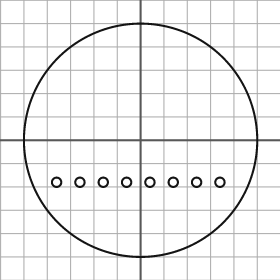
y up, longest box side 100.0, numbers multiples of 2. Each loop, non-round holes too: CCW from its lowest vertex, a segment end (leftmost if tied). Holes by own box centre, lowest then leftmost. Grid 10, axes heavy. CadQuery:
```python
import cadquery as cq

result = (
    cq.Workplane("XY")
    .moveTo(0.0, 0.0)
    .circle(50.0)
    .moveTo(-36.0, -18.0)
    .circle(2.0)
    .moveTo(-26.0, -18.0)
    .circle(2.0)
    .moveTo(-16.0, -18.0)
    .circle(2.0)
    .moveTo(-6.0, -18.0)
    .circle(2.0)
    .moveTo(4.0, -18.0)
    .circle(2.0)
    .moveTo(14.0, -18.0)
    .circle(2.0)
    .moveTo(24.0, -18.0)
    .circle(2.0)
    .moveTo(34.0, -18.0)
    .circle(2.0)
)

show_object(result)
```